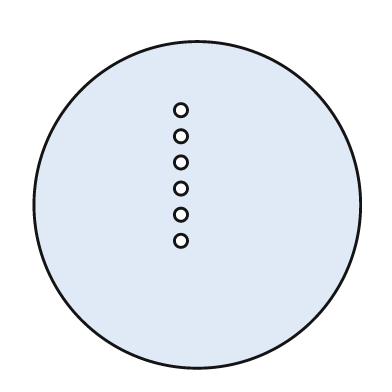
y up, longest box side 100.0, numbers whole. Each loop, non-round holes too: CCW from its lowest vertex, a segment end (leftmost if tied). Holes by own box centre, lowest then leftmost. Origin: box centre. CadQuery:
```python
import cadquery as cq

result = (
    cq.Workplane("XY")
    .moveTo(0.0, 0.0)
    .circle(50.0)
    .moveTo(-5.0, -11.0)
    .circle(2.0)
    .moveTo(-5.0, -3.0)
    .circle(2.0)
    .moveTo(-5.0, 5.0)
    .circle(2.0)
    .moveTo(-5.0, 13.0)
    .circle(2.0)
    .moveTo(-5.0, 21.0)
    .circle(2.0)
    .moveTo(-5.0, 29.0)
    .circle(2.0)
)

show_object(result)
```